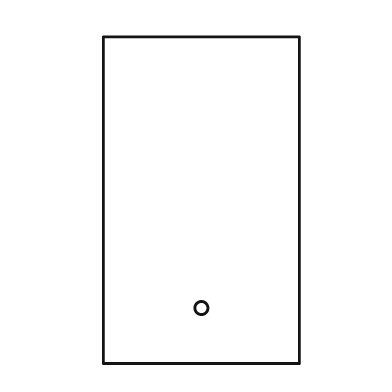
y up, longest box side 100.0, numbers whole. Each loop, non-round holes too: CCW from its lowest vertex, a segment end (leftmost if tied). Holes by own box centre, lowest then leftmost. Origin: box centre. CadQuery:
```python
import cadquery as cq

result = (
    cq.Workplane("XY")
    .moveTo(-30.0, -50.0)
    .lineTo(30.0, -50.0)
    .lineTo(30.0, 50.0)
    .lineTo(-30.0, 50.0)
    .close()
    .moveTo(0.0, -33.0)
    .circle(2.0)
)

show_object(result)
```